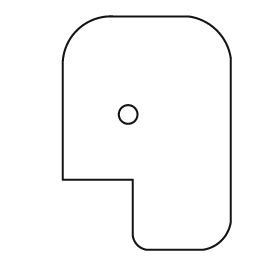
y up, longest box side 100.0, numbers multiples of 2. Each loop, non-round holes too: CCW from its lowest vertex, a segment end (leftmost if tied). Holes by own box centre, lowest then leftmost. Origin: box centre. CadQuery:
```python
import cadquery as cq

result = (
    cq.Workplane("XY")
    .moveTo(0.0, -50.0)
    .lineTo(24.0, -50.0)
    .threePointArc((32.0, -46.0), (36.0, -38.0))
    .lineTo(36.0, 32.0)
    .threePointArc((30.0, 44.0), (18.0, 50.0))
    .lineTo(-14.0, 50.0)
    .threePointArc((-30.0, 44.0), (-36.0, 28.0))
    .lineTo(-36.0, -20.0)
    .lineTo(-6.0, -20.0)
    .lineTo(-6.0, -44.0)
    .threePointArc((-4.0, -48.0), (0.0, -50.0))
    .close()
    .moveTo(-8.0, 8.0)
    .circle(4.0)
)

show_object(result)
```